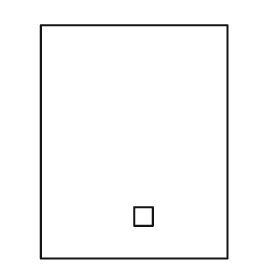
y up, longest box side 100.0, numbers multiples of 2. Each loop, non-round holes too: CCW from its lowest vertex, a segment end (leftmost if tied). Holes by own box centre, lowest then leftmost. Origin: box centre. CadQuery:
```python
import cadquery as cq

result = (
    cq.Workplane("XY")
    .moveTo(-40.0, -50.0)
    .lineTo(40.0, -50.0)
    .lineTo(40.0, 50.0)
    .lineTo(-40.0, 50.0)
    .close()
    .moveTo(0.0, -36.0)
    .lineTo(8.0, -36.0)
    .lineTo(8.0, -28.0)
    .lineTo(0.0, -28.0)
    .close()
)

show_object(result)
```